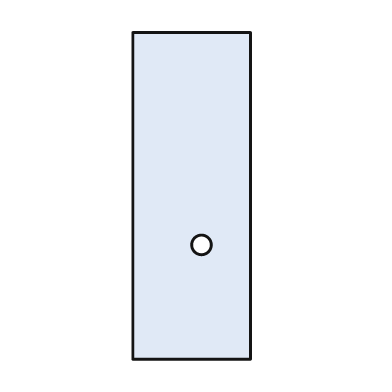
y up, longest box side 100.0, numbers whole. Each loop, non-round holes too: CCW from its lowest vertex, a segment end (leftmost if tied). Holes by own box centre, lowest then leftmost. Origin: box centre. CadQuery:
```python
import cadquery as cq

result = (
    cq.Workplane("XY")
    .moveTo(-18.0, -50.0)
    .lineTo(18.0, -50.0)
    .lineTo(18.0, 50.0)
    .lineTo(-18.0, 50.0)
    .close()
    .moveTo(3.0, -15.0)
    .circle(3.0)
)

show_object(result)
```